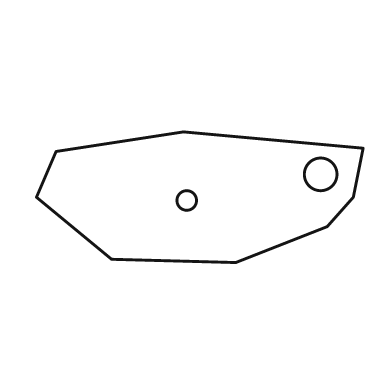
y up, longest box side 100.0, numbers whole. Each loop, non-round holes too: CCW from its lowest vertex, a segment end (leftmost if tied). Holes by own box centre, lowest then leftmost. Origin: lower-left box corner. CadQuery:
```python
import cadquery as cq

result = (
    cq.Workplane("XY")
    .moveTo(61.0, 0.0)
    .lineTo(89.0, 11.0)
    .lineTo(97.0, 20.0)
    .lineTo(100.0, 35.0)
    .lineTo(45.0, 40.0)
    .lineTo(6.0, 34.0)
    .lineTo(0.0, 20.0)
    .lineTo(23.0, 1.0)
    .close()
    .moveTo(46.0, 19.0)
    .circle(3.0)
    .moveTo(87.0, 27.0)
    .circle(5.0)
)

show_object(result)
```